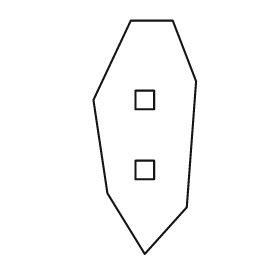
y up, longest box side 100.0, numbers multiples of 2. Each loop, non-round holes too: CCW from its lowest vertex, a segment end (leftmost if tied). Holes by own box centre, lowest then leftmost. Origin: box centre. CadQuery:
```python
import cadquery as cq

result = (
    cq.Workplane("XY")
    .moveTo(0.0, -50.0)
    .lineTo(18.0, -30.0)
    .lineTo(22.0, 24.0)
    .lineTo(12.0, 50.0)
    .lineTo(-6.0, 50.0)
    .lineTo(-22.0, 16.0)
    .lineTo(-16.0, -24.0)
    .close()
    .moveTo(-4.0, -18.0)
    .lineTo(4.0, -18.0)
    .lineTo(4.0, -10.0)
    .lineTo(-4.0, -10.0)
    .close()
    .moveTo(-4.0, 12.0)
    .lineTo(4.0, 12.0)
    .lineTo(4.0, 20.0)
    .lineTo(-4.0, 20.0)
    .close()
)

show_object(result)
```